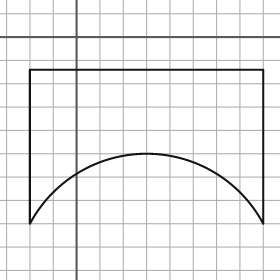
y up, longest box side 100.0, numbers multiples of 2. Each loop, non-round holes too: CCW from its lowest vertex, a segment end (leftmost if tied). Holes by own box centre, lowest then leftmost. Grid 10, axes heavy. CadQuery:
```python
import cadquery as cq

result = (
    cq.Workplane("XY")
    .moveTo(-20.0, -80.0)
    .threePointArc((30.0, -50.0), (80.0, -80.0))
    .lineTo(80.0, -14.0)
    .lineTo(-20.0, -14.0)
    .close()
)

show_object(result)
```